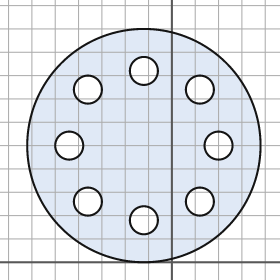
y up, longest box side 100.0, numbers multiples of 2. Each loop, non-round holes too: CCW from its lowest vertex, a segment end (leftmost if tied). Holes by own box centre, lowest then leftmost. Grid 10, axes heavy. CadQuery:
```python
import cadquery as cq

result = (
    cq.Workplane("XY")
    .moveTo(-12.0, 50.0)
    .circle(50.0)
    .moveTo(-12.0, 18.0)
    .circle(6.0)
    .moveTo(-36.0, 26.0)
    .circle(6.0)
    .moveTo(12.0, 26.0)
    .circle(6.0)
    .moveTo(-44.0, 50.0)
    .circle(6.0)
    .moveTo(20.0, 50.0)
    .circle(6.0)
    .moveTo(-36.0, 74.0)
    .circle(6.0)
    .moveTo(12.0, 74.0)
    .circle(6.0)
    .moveTo(-12.0, 82.0)
    .circle(6.0)
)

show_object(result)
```